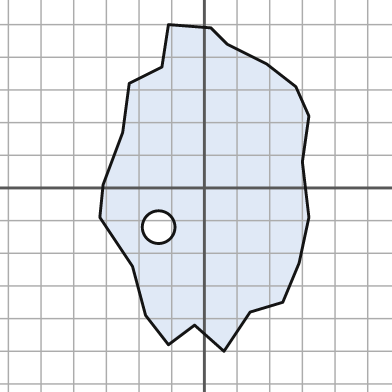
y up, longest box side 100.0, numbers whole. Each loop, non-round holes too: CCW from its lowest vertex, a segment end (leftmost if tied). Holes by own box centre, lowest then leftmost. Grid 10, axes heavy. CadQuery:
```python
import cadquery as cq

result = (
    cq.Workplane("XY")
    .moveTo(6.0, -50.0)
    .lineTo(14.0, -38.0)
    .lineTo(24.0, -35.0)
    .lineTo(29.0, -23.0)
    .lineTo(32.0, -9.0)
    .lineTo(30.0, 8.0)
    .lineTo(32.0, 22.0)
    .lineTo(28.0, 31.0)
    .lineTo(19.0, 38.0)
    .lineTo(7.0, 44.0)
    .lineTo(2.0, 49.0)
    .lineTo(-11.0, 50.0)
    .lineTo(-13.0, 37.0)
    .lineTo(-23.0, 32.0)
    .lineTo(-25.0, 17.0)
    .lineTo(-31.0, 1.0)
    .lineTo(-32.0, -9.0)
    .lineTo(-22.0, -24.0)
    .lineTo(-18.0, -39.0)
    .lineTo(-11.0, -48.0)
    .lineTo(-3.0, -42.0)
    .close()
    .moveTo(-14.0, -12.0)
    .circle(5.0)
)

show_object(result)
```